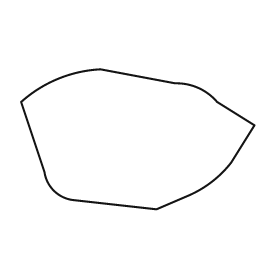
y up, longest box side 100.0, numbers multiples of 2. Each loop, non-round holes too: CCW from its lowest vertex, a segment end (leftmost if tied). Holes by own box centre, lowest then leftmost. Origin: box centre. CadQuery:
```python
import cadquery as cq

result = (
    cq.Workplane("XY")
    .moveTo(8.0, -30.0)
    .lineTo(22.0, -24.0)
    .threePointArc((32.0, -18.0), (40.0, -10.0))
    .lineTo(50.0, 6.0)
    .lineTo(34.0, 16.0)
    .threePointArc((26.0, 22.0), (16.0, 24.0))
    .lineTo(-16.0, 30.0)
    .threePointArc((-34.0, 26.0), (-50.0, 16.0))
    .lineTo(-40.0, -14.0)
    .threePointArc((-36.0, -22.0), (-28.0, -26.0))
    .close()
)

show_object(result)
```